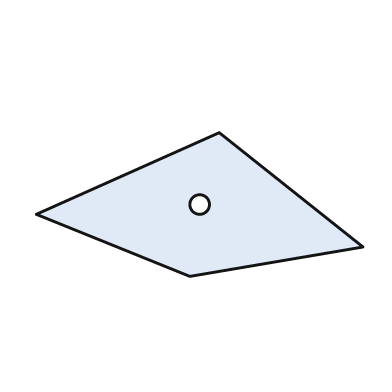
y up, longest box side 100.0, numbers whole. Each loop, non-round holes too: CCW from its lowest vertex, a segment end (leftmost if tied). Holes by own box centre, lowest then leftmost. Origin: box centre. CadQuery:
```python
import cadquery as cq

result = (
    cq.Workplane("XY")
    .moveTo(-3.0, -22.0)
    .lineTo(50.0, -13.0)
    .lineTo(6.0, 22.0)
    .lineTo(-50.0, -3.0)
    .close()
    .moveTo(0.0, 0.0)
    .circle(3.0)
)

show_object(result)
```